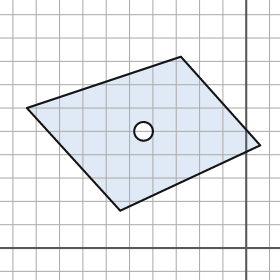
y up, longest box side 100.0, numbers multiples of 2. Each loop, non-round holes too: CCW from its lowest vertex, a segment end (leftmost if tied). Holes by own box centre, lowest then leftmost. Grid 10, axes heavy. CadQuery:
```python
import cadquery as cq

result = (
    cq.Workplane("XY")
    .moveTo(-54.0, 16.0)
    .lineTo(6.0, 44.0)
    .lineTo(-28.0, 82.0)
    .lineTo(-94.0, 60.0)
    .close()
    .moveTo(-44.0, 50.0)
    .circle(4.0)
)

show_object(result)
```